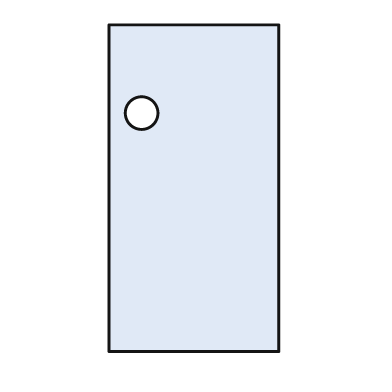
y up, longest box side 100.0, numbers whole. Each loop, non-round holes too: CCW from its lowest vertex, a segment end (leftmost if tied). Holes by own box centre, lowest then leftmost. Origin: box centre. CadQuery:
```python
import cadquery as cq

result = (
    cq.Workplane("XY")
    .moveTo(-26.0, -50.0)
    .lineTo(26.0, -50.0)
    .lineTo(26.0, 50.0)
    .lineTo(-26.0, 50.0)
    .close()
    .moveTo(-16.0, 23.0)
    .circle(5.0)
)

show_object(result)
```